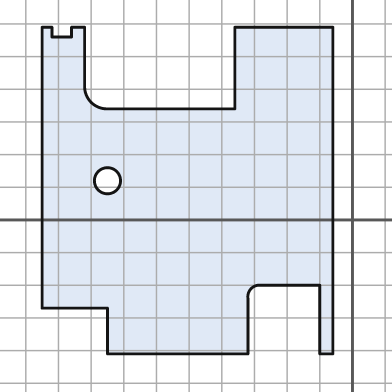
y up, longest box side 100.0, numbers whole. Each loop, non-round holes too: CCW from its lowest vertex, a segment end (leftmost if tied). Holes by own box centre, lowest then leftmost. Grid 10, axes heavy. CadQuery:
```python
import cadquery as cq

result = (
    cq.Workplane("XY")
    .moveTo(-75.0, -41.0)
    .lineTo(-32.0, -41.0)
    .lineTo(-32.0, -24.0)
    .threePointArc((-31.0, -21.0), (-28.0, -20.0))
    .lineTo(-10.0, -20.0)
    .lineTo(-10.0, -41.0)
    .lineTo(-6.0, -41.0)
    .lineTo(-6.0, 59.0)
    .lineTo(-36.0, 59.0)
    .lineTo(-36.0, 34.0)
    .lineTo(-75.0, 34.0)
    .threePointArc((-80.0, 36.0), (-82.0, 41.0))
    .lineTo(-82.0, 59.0)
    .lineTo(-86.0, 59.0)
    .lineTo(-86.0, 56.0)
    .lineTo(-92.0, 56.0)
    .lineTo(-92.0, 59.0)
    .lineTo(-95.0, 59.0)
    .lineTo(-95.0, -27.0)
    .lineTo(-75.0, -27.0)
    .close()
    .moveTo(-75.0, 12.0)
    .circle(4.0)
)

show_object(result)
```